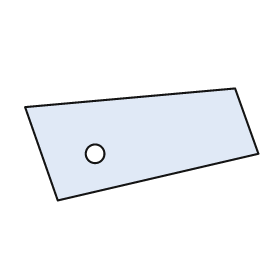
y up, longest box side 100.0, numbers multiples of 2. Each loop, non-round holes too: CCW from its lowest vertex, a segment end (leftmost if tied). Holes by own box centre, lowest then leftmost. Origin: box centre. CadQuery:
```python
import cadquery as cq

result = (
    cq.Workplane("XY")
    .moveTo(-36.0, -24.0)
    .lineTo(50.0, -4.0)
    .lineTo(40.0, 24.0)
    .lineTo(-50.0, 16.0)
    .close()
    .moveTo(-20.0, -4.0)
    .circle(4.0)
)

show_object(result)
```